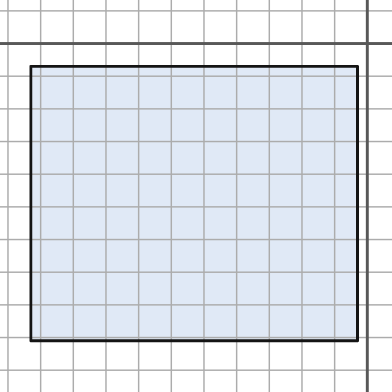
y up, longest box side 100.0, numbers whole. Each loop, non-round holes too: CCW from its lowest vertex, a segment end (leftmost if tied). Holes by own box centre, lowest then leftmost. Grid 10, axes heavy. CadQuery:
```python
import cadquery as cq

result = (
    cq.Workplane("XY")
    .moveTo(-103.0, -91.0)
    .lineTo(-3.0, -91.0)
    .lineTo(-3.0, -7.0)
    .lineTo(-103.0, -7.0)
    .close()
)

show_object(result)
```